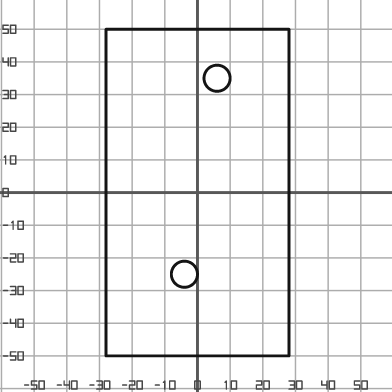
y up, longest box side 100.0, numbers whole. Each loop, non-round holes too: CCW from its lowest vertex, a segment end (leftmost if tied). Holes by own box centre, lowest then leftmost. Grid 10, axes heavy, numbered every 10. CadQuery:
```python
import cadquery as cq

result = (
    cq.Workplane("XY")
    .moveTo(-28.0, -50.0)
    .lineTo(28.0, -50.0)
    .lineTo(28.0, 50.0)
    .lineTo(-28.0, 50.0)
    .close()
    .moveTo(-4.0, -25.0)
    .circle(4.0)
    .moveTo(6.0, 35.0)
    .circle(4.0)
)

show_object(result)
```